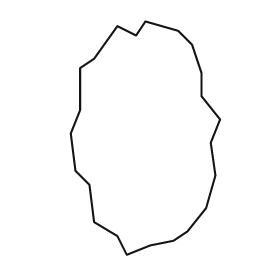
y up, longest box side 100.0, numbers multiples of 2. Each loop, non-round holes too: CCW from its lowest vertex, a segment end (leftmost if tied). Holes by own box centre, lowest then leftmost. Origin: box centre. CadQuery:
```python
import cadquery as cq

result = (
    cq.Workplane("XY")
    .moveTo(-8.0, -50.0)
    .lineTo(2.0, -46.0)
    .lineTo(12.0, -44.0)
    .lineTo(18.0, -40.0)
    .lineTo(26.0, -30.0)
    .lineTo(30.0, -16.0)
    .lineTo(28.0, -2.0)
    .lineTo(32.0, 8.0)
    .lineTo(24.0, 18.0)
    .lineTo(24.0, 28.0)
    .lineTo(20.0, 40.0)
    .lineTo(14.0, 46.0)
    .lineTo(0.0, 50.0)
    .lineTo(-4.0, 44.0)
    .lineTo(-12.0, 48.0)
    .lineTo(-22.0, 34.0)
    .lineTo(-28.0, 30.0)
    .lineTo(-28.0, 12.0)
    .lineTo(-32.0, 2.0)
    .lineTo(-30.0, -14.0)
    .lineTo(-24.0, -20.0)
    .lineTo(-22.0, -36.0)
    .lineTo(-12.0, -42.0)
    .close()
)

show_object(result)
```